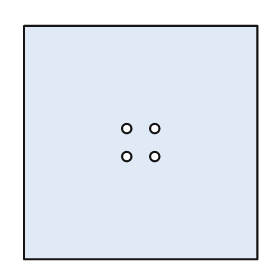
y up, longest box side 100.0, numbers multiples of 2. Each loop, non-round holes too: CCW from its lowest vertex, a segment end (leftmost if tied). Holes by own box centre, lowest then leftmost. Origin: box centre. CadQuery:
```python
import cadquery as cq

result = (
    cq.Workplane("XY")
    .moveTo(-50.0, -50.0)
    .lineTo(50.0, -50.0)
    .lineTo(50.0, 50.0)
    .lineTo(-50.0, 50.0)
    .close()
    .moveTo(-6.0, -6.0)
    .circle(2.0)
    .moveTo(6.0, -6.0)
    .circle(2.0)
    .moveTo(-6.0, 6.0)
    .circle(2.0)
    .moveTo(6.0, 6.0)
    .circle(2.0)
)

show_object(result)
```